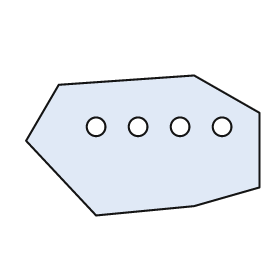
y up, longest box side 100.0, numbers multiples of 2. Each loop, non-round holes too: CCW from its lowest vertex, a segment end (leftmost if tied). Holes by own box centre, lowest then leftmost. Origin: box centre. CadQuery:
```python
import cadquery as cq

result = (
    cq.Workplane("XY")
    .moveTo(-20.0, -30.0)
    .lineTo(22.0, -26.0)
    .lineTo(50.0, -18.0)
    .lineTo(50.0, 14.0)
    .lineTo(22.0, 30.0)
    .lineTo(-36.0, 26.0)
    .lineTo(-50.0, 2.0)
    .close()
    .moveTo(-20.0, 8.0)
    .circle(4.0)
    .moveTo(-2.0, 8.0)
    .circle(4.0)
    .moveTo(16.0, 8.0)
    .circle(4.0)
    .moveTo(34.0, 8.0)
    .circle(4.0)
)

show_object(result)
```